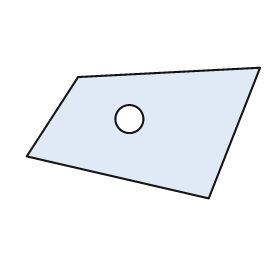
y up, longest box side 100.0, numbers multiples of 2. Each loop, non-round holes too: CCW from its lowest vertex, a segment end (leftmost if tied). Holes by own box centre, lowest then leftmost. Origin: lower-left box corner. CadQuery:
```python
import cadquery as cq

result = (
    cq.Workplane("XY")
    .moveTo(78.0, 0.0)
    .lineTo(100.0, 56.0)
    .lineTo(22.0, 52.0)
    .lineTo(0.0, 18.0)
    .close()
    .moveTo(44.0, 34.0)
    .circle(6.0)
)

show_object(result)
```